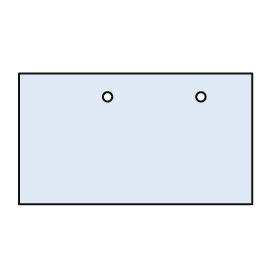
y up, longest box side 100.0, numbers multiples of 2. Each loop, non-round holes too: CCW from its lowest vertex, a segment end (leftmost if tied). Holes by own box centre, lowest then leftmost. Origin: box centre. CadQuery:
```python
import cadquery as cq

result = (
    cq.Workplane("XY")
    .moveTo(-50.0, -28.0)
    .lineTo(50.0, -28.0)
    .lineTo(50.0, 28.0)
    .lineTo(-50.0, 28.0)
    .close()
    .moveTo(-12.0, 18.0)
    .circle(2.0)
    .moveTo(28.0, 18.0)
    .circle(2.0)
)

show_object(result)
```